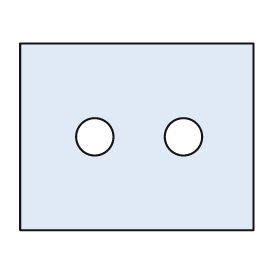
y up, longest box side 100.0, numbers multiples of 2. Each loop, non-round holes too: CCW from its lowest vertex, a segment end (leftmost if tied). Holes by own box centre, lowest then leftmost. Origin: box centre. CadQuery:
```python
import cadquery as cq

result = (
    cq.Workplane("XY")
    .moveTo(-50.0, -40.0)
    .lineTo(50.0, -40.0)
    .lineTo(50.0, 40.0)
    .lineTo(-50.0, 40.0)
    .close()
    .moveTo(-18.0, 0.0)
    .circle(8.0)
    .moveTo(20.0, 0.0)
    .circle(8.0)
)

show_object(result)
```